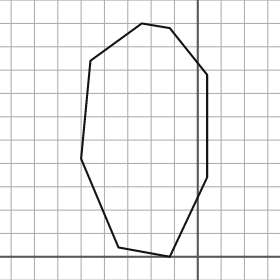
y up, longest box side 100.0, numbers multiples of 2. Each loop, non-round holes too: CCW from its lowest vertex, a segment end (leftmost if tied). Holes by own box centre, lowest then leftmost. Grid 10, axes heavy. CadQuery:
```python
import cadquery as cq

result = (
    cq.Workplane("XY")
    .moveTo(-12.0, 0.0)
    .lineTo(4.0, 34.0)
    .lineTo(4.0, 78.0)
    .lineTo(-12.0, 98.0)
    .lineTo(-24.0, 100.0)
    .lineTo(-46.0, 84.0)
    .lineTo(-50.0, 42.0)
    .lineTo(-34.0, 4.0)
    .close()
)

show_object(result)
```